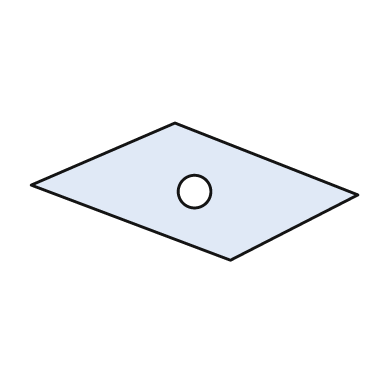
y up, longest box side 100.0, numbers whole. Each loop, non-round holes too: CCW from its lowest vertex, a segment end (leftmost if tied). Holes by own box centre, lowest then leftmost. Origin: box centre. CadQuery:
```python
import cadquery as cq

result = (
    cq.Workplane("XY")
    .moveTo(11.0, -21.0)
    .lineTo(50.0, -1.0)
    .lineTo(-6.0, 21.0)
    .lineTo(-50.0, 2.0)
    .close()
    .moveTo(0.0, 0.0)
    .circle(5.0)
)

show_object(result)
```